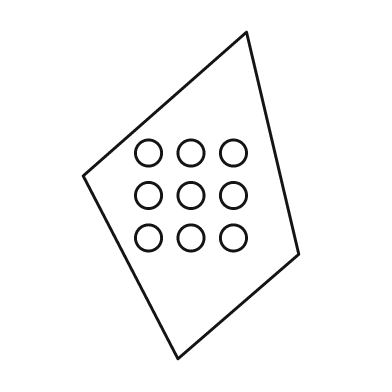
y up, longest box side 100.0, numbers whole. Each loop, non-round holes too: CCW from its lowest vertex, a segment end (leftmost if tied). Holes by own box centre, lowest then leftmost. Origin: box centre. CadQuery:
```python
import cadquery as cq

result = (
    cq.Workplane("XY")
    .moveTo(-4.0, -50.0)
    .lineTo(33.0, -18.0)
    .lineTo(17.0, 50.0)
    .lineTo(-33.0, 6.0)
    .close()
    .moveTo(-13.0, -13.0)
    .circle(4.0)
    .moveTo(0.0, -13.0)
    .circle(4.0)
    .moveTo(13.0, -13.0)
    .circle(4.0)
    .moveTo(-13.0, 0.0)
    .circle(4.0)
    .moveTo(0.0, 0.0)
    .circle(4.0)
    .moveTo(13.0, 0.0)
    .circle(4.0)
    .moveTo(-13.0, 13.0)
    .circle(4.0)
    .moveTo(0.0, 13.0)
    .circle(4.0)
    .moveTo(13.0, 13.0)
    .circle(4.0)
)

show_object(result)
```